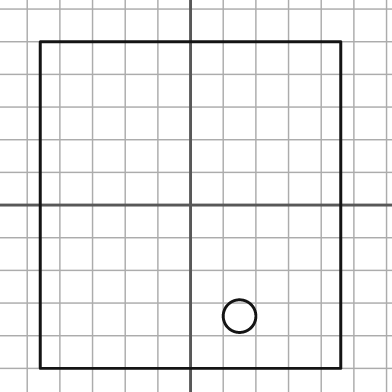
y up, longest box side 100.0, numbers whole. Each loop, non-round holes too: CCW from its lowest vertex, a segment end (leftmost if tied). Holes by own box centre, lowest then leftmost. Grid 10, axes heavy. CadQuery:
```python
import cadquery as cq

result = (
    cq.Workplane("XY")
    .moveTo(-46.0, -50.0)
    .lineTo(46.0, -50.0)
    .lineTo(46.0, 50.0)
    .lineTo(-46.0, 50.0)
    .close()
    .moveTo(15.0, -34.0)
    .circle(5.0)
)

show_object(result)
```